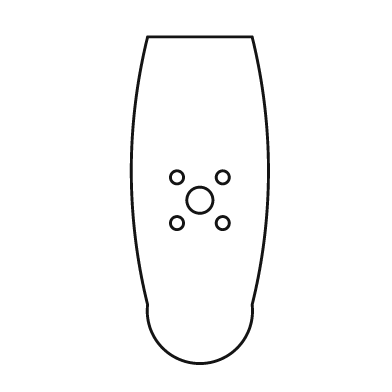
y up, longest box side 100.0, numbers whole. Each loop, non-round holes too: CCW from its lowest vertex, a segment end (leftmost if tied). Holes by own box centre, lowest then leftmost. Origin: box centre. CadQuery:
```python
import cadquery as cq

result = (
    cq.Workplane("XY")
    .moveTo(-16.0, -32.0)
    .threePointArc((0.0, -50.0), (16.0, -32.0))
    .threePointArc((21.0, 9.0), (16.0, 50.0))
    .lineTo(-16.0, 50.0)
    .threePointArc((-21.0, 9.0), (-16.0, -32.0))
    .close()
    .moveTo(-7.0, -7.0)
    .circle(2.0)
    .moveTo(7.0, -7.0)
    .circle(2.0)
    .moveTo(0.0, 0.0)
    .circle(4.0)
    .moveTo(-7.0, 7.0)
    .circle(2.0)
    .moveTo(7.0, 7.0)
    .circle(2.0)
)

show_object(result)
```